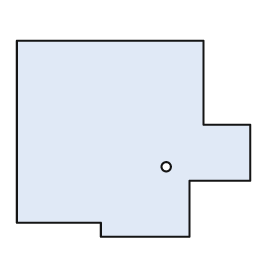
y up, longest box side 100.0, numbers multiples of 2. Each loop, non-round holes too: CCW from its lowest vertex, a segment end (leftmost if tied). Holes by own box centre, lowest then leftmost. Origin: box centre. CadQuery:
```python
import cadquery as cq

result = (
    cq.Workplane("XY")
    .moveTo(-14.0, -42.0)
    .lineTo(24.0, -42.0)
    .lineTo(24.0, -18.0)
    .lineTo(50.0, -18.0)
    .lineTo(50.0, 6.0)
    .lineTo(30.0, 6.0)
    .lineTo(30.0, 42.0)
    .lineTo(-50.0, 42.0)
    .lineTo(-50.0, -36.0)
    .lineTo(-14.0, -36.0)
    .close()
    .moveTo(14.0, -12.0)
    .circle(2.0)
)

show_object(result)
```